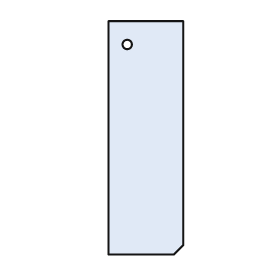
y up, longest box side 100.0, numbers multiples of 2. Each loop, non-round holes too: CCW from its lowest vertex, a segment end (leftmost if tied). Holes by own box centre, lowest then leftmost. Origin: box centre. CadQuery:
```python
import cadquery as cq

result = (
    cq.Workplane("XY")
    .moveTo(-16.0, -50.0)
    .lineTo(12.0, -50.0)
    .lineTo(16.0, -46.0)
    .lineTo(16.0, 50.0)
    .lineTo(-16.0, 50.0)
    .close()
    .moveTo(-8.0, 40.0)
    .circle(2.0)
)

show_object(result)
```